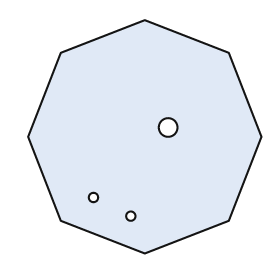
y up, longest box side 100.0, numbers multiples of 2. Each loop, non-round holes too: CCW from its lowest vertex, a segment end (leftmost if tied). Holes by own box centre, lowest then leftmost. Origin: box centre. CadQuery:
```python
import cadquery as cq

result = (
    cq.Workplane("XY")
    .moveTo(0.0, -50.0)
    .lineTo(36.0, -36.0)
    .lineTo(50.0, 0.0)
    .lineTo(36.0, 36.0)
    .lineTo(0.0, 50.0)
    .lineTo(-36.0, 36.0)
    .lineTo(-50.0, 0.0)
    .lineTo(-36.0, -36.0)
    .close()
    .moveTo(-6.0, -34.0)
    .circle(2.0)
    .moveTo(-22.0, -26.0)
    .circle(2.0)
    .moveTo(10.0, 4.0)
    .circle(4.0)
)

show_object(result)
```